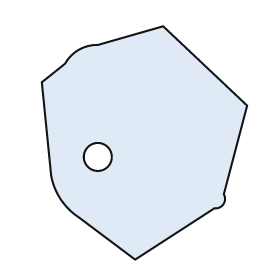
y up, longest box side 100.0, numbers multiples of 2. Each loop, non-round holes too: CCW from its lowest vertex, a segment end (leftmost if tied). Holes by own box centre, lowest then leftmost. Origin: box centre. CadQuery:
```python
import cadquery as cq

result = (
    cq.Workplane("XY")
    .moveTo(-4.0, -50.0)
    .lineTo(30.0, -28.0)
    .threePointArc((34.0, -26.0), (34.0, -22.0))
    .lineTo(44.0, 16.0)
    .lineTo(8.0, 50.0)
    .lineTo(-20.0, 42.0)
    .threePointArc((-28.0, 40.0), (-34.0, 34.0))
    .lineTo(-44.0, 26.0)
    .lineTo(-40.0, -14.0)
    .threePointArc((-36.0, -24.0), (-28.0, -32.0))
    .close()
    .moveTo(-20.0, -6.0)
    .circle(6.0)
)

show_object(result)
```